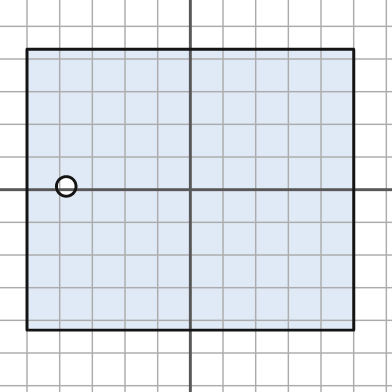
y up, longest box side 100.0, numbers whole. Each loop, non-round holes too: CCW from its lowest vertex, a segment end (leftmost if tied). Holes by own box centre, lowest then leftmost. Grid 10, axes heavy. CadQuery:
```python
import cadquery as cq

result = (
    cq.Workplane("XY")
    .moveTo(-50.0, -43.0)
    .lineTo(50.0, -43.0)
    .lineTo(50.0, 43.0)
    .lineTo(-50.0, 43.0)
    .close()
    .moveTo(-38.0, 1.0)
    .circle(3.0)
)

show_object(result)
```